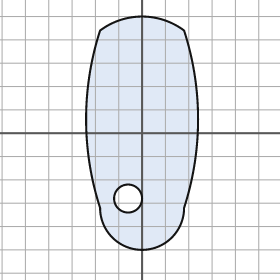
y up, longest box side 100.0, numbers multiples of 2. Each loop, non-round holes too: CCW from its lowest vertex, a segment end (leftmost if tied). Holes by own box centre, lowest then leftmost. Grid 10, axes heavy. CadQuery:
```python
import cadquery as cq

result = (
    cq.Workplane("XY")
    .moveTo(-18.0, -32.0)
    .threePointArc((0.0, -50.0), (18.0, -32.0))
    .threePointArc((24.0, 6.0), (18.0, 44.0))
    .threePointArc((0.0, 50.0), (-18.0, 44.0))
    .threePointArc((-24.0, 6.0), (-18.0, -32.0))
    .close()
    .moveTo(-6.0, -28.0)
    .circle(6.0)
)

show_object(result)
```